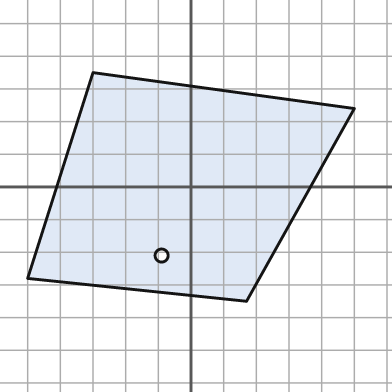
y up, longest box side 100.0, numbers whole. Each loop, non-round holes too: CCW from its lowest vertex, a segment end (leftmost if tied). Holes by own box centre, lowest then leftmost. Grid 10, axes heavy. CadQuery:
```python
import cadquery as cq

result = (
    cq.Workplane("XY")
    .moveTo(17.0, -35.0)
    .lineTo(50.0, 24.0)
    .lineTo(-30.0, 35.0)
    .lineTo(-50.0, -28.0)
    .close()
    .moveTo(-9.0, -21.0)
    .circle(2.0)
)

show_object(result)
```